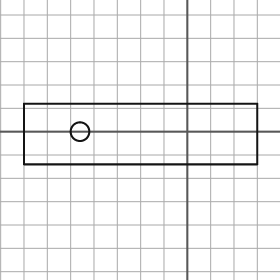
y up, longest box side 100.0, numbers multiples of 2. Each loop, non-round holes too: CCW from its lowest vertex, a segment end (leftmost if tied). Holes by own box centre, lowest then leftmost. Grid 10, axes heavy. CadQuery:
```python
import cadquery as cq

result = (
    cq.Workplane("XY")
    .moveTo(-70.0, -14.0)
    .lineTo(30.0, -14.0)
    .lineTo(30.0, 12.0)
    .lineTo(-70.0, 12.0)
    .close()
    .moveTo(-46.0, 0.0)
    .circle(4.0)
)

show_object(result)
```